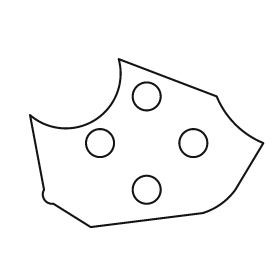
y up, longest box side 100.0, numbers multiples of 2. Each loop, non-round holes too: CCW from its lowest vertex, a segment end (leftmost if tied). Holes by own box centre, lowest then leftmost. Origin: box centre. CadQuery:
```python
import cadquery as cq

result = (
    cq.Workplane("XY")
    .moveTo(-24.0, -36.0)
    .lineTo(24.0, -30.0)
    .threePointArc((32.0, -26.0), (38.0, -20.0))
    .lineTo(50.0, 0.0)
    .threePointArc((38.0, 8.0), (30.0, 20.0))
    .lineTo(-12.0, 36.0)
    .threePointArc((-22.0, 10.0), (-50.0, 12.0))
    .lineTo(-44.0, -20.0)
    .threePointArc((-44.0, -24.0), (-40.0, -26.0))
    .close()
    .moveTo(0.0, -20.0)
    .circle(6.0)
    .moveTo(-20.0, 0.0)
    .circle(6.0)
    .moveTo(20.0, 0.0)
    .circle(6.0)
    .moveTo(0.0, 20.0)
    .circle(6.0)
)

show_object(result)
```